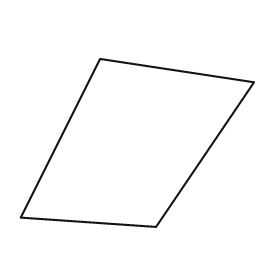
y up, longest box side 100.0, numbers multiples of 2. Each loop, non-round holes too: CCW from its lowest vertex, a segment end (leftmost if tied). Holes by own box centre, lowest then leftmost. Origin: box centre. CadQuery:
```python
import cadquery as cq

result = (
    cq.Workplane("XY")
    .moveTo(8.0, -36.0)
    .lineTo(50.0, 26.0)
    .lineTo(-16.0, 36.0)
    .lineTo(-50.0, -32.0)
    .close()
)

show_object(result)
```